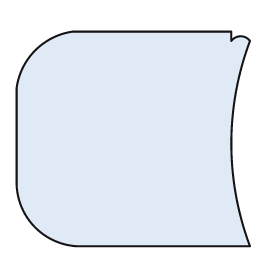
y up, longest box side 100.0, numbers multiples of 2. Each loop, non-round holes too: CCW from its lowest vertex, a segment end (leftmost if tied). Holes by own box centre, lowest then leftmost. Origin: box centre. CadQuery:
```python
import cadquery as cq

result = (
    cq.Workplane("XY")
    .moveTo(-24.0, -46.0)
    .lineTo(50.0, -46.0)
    .threePointArc((42.0, -2.0), (50.0, 42.0))
    .threePointArc((46.0, 44.0), (42.0, 42.0))
    .lineTo(42.0, 46.0)
    .lineTo(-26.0, 46.0)
    .threePointArc((-42.0, 38.0), (-50.0, 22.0))
    .lineTo(-50.0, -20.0)
    .threePointArc((-42.0, -38.0), (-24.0, -46.0))
    .close()
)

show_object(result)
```